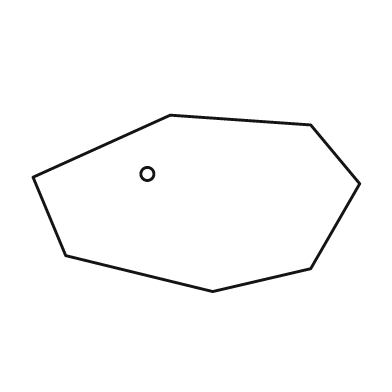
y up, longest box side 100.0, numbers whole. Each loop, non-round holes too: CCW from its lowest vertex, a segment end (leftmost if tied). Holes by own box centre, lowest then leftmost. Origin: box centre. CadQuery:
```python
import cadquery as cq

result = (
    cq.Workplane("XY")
    .moveTo(5.0, -27.0)
    .lineTo(35.0, -20.0)
    .lineTo(50.0, 6.0)
    .lineTo(35.0, 24.0)
    .lineTo(-8.0, 27.0)
    .lineTo(-50.0, 8.0)
    .lineTo(-40.0, -16.0)
    .close()
    .moveTo(-15.0, 9.0)
    .circle(2.0)
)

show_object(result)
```